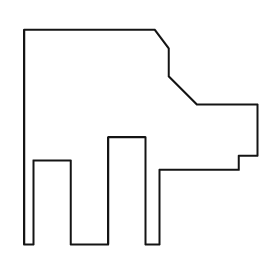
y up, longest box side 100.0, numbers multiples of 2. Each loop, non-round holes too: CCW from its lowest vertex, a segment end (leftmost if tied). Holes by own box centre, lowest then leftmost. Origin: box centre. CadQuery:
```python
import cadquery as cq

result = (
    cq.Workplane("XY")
    .moveTo(-50.0, -46.0)
    .lineTo(-46.0, -46.0)
    .lineTo(-46.0, -10.0)
    .lineTo(-30.0, -10.0)
    .lineTo(-30.0, -46.0)
    .lineTo(-14.0, -46.0)
    .lineTo(-14.0, 0.0)
    .lineTo(2.0, 0.0)
    .lineTo(2.0, -46.0)
    .lineTo(8.0, -46.0)
    .lineTo(8.0, -14.0)
    .lineTo(42.0, -14.0)
    .lineTo(42.0, -8.0)
    .lineTo(50.0, -8.0)
    .lineTo(50.0, 14.0)
    .lineTo(24.0, 14.0)
    .lineTo(12.0, 26.0)
    .lineTo(12.0, 38.0)
    .lineTo(6.0, 46.0)
    .lineTo(-50.0, 46.0)
    .close()
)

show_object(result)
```